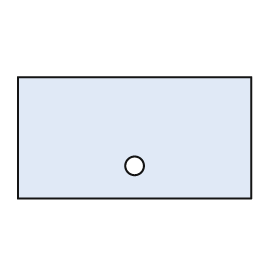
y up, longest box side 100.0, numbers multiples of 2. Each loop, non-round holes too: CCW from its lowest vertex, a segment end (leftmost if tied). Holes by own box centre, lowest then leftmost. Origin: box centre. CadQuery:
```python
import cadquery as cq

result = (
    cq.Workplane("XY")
    .moveTo(-50.0, -26.0)
    .lineTo(50.0, -26.0)
    .lineTo(50.0, 26.0)
    .lineTo(-50.0, 26.0)
    .close()
    .moveTo(0.0, -12.0)
    .circle(4.0)
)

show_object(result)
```